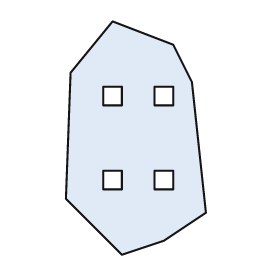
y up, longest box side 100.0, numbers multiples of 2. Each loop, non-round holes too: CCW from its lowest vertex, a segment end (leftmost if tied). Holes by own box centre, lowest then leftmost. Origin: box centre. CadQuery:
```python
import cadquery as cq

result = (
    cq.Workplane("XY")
    .moveTo(-6.0, -50.0)
    .lineTo(12.0, -44.0)
    .lineTo(30.0, -32.0)
    .lineTo(24.0, 24.0)
    .lineTo(16.0, 40.0)
    .lineTo(-10.0, 50.0)
    .lineTo(-28.0, 28.0)
    .lineTo(-30.0, -26.0)
    .close()
    .moveTo(-14.0, -22.0)
    .lineTo(-6.0, -22.0)
    .lineTo(-6.0, -14.0)
    .lineTo(-14.0, -14.0)
    .close()
    .moveTo(8.0, -22.0)
    .lineTo(16.0, -22.0)
    .lineTo(16.0, -14.0)
    .lineTo(8.0, -14.0)
    .close()
    .moveTo(-14.0, 14.0)
    .lineTo(-6.0, 14.0)
    .lineTo(-6.0, 22.0)
    .lineTo(-14.0, 22.0)
    .close()
    .moveTo(8.0, 14.0)
    .lineTo(16.0, 14.0)
    .lineTo(16.0, 22.0)
    .lineTo(8.0, 22.0)
    .close()
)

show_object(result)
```